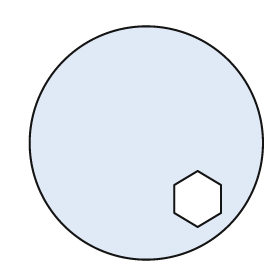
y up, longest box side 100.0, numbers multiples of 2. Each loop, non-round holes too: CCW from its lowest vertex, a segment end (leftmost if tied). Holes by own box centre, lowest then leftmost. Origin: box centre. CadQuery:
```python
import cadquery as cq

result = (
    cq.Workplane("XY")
    .moveTo(0.0, 0.0)
    .circle(50.0)
    .moveTo(22.0, -36.0)
    .lineTo(32.0, -30.0)
    .lineTo(32.0, -18.0)
    .lineTo(22.0, -12.0)
    .lineTo(12.0, -18.0)
    .lineTo(12.0, -30.0)
    .close()
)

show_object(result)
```